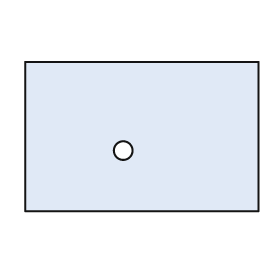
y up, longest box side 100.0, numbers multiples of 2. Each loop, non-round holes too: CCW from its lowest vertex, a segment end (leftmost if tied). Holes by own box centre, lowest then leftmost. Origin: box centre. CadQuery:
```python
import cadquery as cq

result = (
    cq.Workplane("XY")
    .moveTo(-50.0, -32.0)
    .lineTo(50.0, -32.0)
    .lineTo(50.0, 32.0)
    .lineTo(-50.0, 32.0)
    .close()
    .moveTo(-8.0, -6.0)
    .circle(4.0)
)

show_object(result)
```